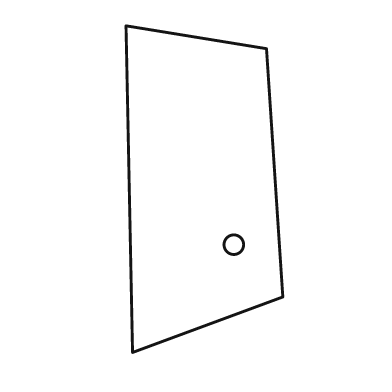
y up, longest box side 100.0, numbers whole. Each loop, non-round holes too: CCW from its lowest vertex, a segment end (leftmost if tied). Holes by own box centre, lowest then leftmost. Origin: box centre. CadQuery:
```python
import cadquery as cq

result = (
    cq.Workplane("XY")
    .moveTo(-22.0, -50.0)
    .lineTo(24.0, -33.0)
    .lineTo(19.0, 43.0)
    .lineTo(-24.0, 50.0)
    .close()
    .moveTo(9.0, -17.0)
    .circle(3.0)
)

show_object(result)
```